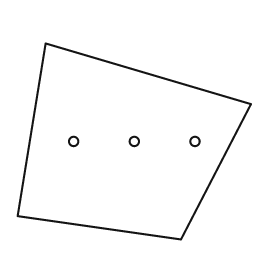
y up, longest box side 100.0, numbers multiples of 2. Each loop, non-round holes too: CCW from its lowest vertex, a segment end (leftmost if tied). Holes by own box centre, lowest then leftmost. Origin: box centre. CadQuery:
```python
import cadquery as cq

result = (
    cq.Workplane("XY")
    .moveTo(20.0, -42.0)
    .lineTo(50.0, 16.0)
    .lineTo(-38.0, 42.0)
    .lineTo(-50.0, -32.0)
    .close()
    .moveTo(-26.0, 0.0)
    .circle(2.0)
    .moveTo(0.0, 0.0)
    .circle(2.0)
    .moveTo(26.0, 0.0)
    .circle(2.0)
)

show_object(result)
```